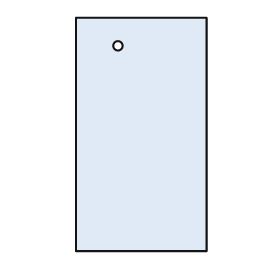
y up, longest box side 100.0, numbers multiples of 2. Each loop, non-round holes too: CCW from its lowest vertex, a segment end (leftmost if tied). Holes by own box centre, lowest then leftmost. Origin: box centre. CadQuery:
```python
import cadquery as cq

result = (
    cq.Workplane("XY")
    .moveTo(-28.0, -50.0)
    .lineTo(28.0, -50.0)
    .lineTo(28.0, 50.0)
    .lineTo(-28.0, 50.0)
    .close()
    .moveTo(-10.0, 38.0)
    .circle(2.0)
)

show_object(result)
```